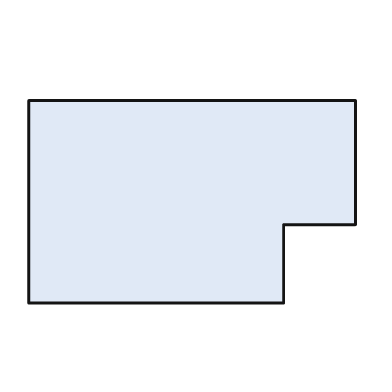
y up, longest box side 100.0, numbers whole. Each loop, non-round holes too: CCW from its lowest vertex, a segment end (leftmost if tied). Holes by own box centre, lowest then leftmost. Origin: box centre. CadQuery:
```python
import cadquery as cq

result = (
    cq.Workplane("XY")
    .moveTo(-50.0, -31.0)
    .lineTo(28.0, -31.0)
    .lineTo(28.0, -7.0)
    .lineTo(50.0, -7.0)
    .lineTo(50.0, 31.0)
    .lineTo(-50.0, 31.0)
    .close()
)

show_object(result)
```